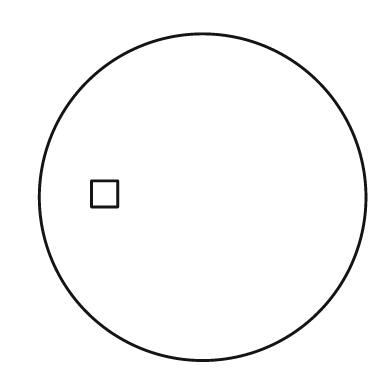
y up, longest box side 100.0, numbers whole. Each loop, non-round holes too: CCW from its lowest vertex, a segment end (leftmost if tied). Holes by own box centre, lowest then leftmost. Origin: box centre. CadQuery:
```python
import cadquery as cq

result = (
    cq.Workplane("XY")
    .moveTo(0.0, 0.0)
    .circle(50.0)
    .moveTo(-34.0, -3.0)
    .lineTo(-26.0, -3.0)
    .lineTo(-26.0, 5.0)
    .lineTo(-34.0, 5.0)
    .close()
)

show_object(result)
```